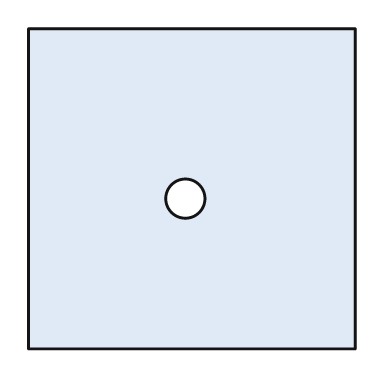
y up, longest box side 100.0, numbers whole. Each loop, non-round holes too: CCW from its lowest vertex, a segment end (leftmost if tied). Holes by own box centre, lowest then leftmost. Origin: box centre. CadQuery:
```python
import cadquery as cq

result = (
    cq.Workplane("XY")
    .moveTo(-50.0, -49.0)
    .lineTo(50.0, -49.0)
    .lineTo(50.0, 49.0)
    .lineTo(-50.0, 49.0)
    .close()
    .moveTo(-2.0, -3.0)
    .circle(6.0)
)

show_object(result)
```